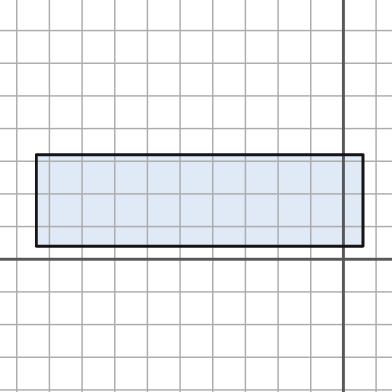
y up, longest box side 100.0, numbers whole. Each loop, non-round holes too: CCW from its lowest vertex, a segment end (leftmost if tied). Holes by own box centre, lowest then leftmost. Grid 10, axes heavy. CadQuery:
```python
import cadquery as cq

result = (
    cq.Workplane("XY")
    .moveTo(-94.0, 4.0)
    .lineTo(6.0, 4.0)
    .lineTo(6.0, 32.0)
    .lineTo(-94.0, 32.0)
    .close()
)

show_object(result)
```